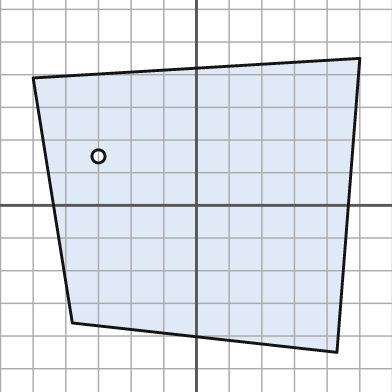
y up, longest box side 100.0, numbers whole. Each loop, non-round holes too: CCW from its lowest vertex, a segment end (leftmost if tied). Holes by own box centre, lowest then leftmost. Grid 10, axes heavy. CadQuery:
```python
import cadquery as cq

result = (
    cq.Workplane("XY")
    .moveTo(43.0, -45.0)
    .lineTo(50.0, 45.0)
    .lineTo(-50.0, 39.0)
    .lineTo(-38.0, -36.0)
    .close()
    .moveTo(-30.0, 15.0)
    .circle(2.0)
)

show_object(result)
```